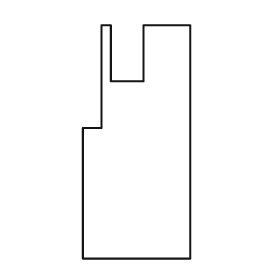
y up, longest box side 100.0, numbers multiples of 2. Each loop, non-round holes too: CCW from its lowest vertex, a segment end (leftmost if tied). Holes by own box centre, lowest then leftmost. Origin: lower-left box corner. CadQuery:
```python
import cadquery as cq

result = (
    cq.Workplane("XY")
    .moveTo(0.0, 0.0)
    .lineTo(46.0, 0.0)
    .lineTo(46.0, 100.0)
    .lineTo(26.0, 100.0)
    .lineTo(26.0, 76.0)
    .lineTo(12.0, 76.0)
    .lineTo(12.0, 100.0)
    .lineTo(8.0, 100.0)
    .lineTo(8.0, 56.0)
    .lineTo(0.0, 56.0)
    .close()
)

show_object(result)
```